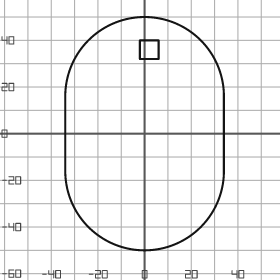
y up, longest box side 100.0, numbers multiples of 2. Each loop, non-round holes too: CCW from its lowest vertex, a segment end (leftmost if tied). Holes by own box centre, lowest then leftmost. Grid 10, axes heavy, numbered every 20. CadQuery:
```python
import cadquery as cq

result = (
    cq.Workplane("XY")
    .moveTo(-34.0, -16.0)
    .threePointArc((0.0, -50.0), (34.0, -16.0))
    .lineTo(34.0, 16.0)
    .threePointArc((0.0, 50.0), (-34.0, 16.0))
    .close()
    .moveTo(-2.0, 32.0)
    .lineTo(6.0, 32.0)
    .lineTo(6.0, 40.0)
    .lineTo(-2.0, 40.0)
    .close()
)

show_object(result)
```